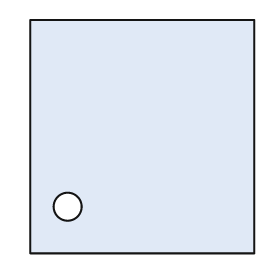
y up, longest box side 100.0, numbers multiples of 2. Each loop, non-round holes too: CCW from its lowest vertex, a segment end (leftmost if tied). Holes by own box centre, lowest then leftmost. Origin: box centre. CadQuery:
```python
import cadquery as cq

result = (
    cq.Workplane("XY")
    .moveTo(-48.0, -50.0)
    .lineTo(48.0, -50.0)
    .lineTo(48.0, 50.0)
    .lineTo(-48.0, 50.0)
    .close()
    .moveTo(-32.0, -30.0)
    .circle(6.0)
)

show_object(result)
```